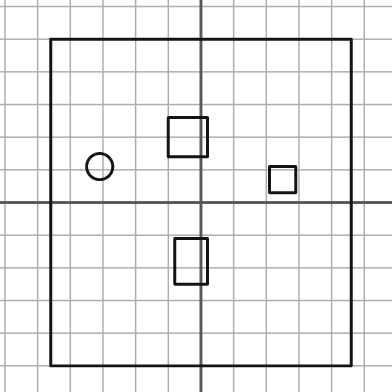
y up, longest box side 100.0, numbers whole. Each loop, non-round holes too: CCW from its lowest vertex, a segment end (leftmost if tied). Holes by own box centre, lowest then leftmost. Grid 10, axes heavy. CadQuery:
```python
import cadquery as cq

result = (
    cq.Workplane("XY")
    .moveTo(-46.0, -50.0)
    .lineTo(46.0, -50.0)
    .lineTo(46.0, 50.0)
    .lineTo(-46.0, 50.0)
    .close()
    .moveTo(-8.0, -25.0)
    .lineTo(2.0, -25.0)
    .lineTo(2.0, -11.0)
    .lineTo(-8.0, -11.0)
    .close()
    .moveTo(21.0, 3.0)
    .lineTo(29.0, 3.0)
    .lineTo(29.0, 11.0)
    .lineTo(21.0, 11.0)
    .close()
    .moveTo(-31.0, 11.0)
    .circle(4.0)
    .moveTo(-10.0, 14.0)
    .lineTo(2.0, 14.0)
    .lineTo(2.0, 26.0)
    .lineTo(-10.0, 26.0)
    .close()
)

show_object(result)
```